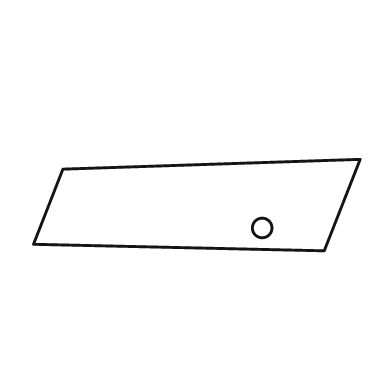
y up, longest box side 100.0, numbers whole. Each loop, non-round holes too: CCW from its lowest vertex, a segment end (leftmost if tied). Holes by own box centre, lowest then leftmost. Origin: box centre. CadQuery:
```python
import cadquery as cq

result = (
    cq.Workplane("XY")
    .moveTo(39.0, -14.0)
    .lineTo(50.0, 14.0)
    .lineTo(-41.0, 11.0)
    .lineTo(-50.0, -12.0)
    .close()
    .moveTo(20.0, -7.0)
    .circle(3.0)
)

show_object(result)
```